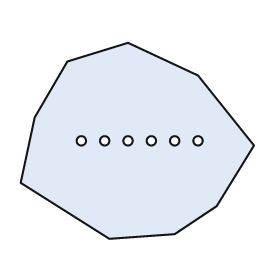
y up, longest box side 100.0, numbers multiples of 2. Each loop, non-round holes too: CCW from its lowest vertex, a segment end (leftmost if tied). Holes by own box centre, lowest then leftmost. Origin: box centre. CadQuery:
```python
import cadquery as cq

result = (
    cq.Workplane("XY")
    .moveTo(-12.0, -42.0)
    .lineTo(16.0, -40.0)
    .lineTo(34.0, -28.0)
    .lineTo(50.0, -2.0)
    .lineTo(26.0, 28.0)
    .lineTo(-4.0, 42.0)
    .lineTo(-30.0, 34.0)
    .lineTo(-44.0, 10.0)
    .lineTo(-50.0, -18.0)
    .close()
    .moveTo(-24.0, 0.0)
    .circle(2.0)
    .moveTo(-14.0, 0.0)
    .circle(2.0)
    .moveTo(-4.0, 0.0)
    .circle(2.0)
    .moveTo(6.0, 0.0)
    .circle(2.0)
    .moveTo(16.0, 0.0)
    .circle(2.0)
    .moveTo(26.0, 0.0)
    .circle(2.0)
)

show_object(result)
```